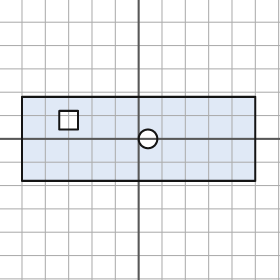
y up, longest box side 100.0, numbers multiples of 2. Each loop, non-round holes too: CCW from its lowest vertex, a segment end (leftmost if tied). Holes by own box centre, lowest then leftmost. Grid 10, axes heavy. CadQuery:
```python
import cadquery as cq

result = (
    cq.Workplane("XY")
    .moveTo(-50.0, -18.0)
    .lineTo(50.0, -18.0)
    .lineTo(50.0, 18.0)
    .lineTo(-50.0, 18.0)
    .close()
    .moveTo(4.0, 0.0)
    .circle(4.0)
    .moveTo(-34.0, 4.0)
    .lineTo(-26.0, 4.0)
    .lineTo(-26.0, 12.0)
    .lineTo(-34.0, 12.0)
    .close()
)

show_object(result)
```